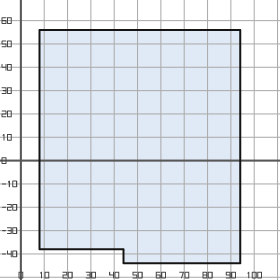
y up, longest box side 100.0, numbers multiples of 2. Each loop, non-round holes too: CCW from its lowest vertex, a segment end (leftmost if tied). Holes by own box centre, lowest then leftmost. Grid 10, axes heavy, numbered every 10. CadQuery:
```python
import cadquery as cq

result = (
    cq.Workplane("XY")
    .moveTo(44.0, -44.0)
    .lineTo(94.0, -44.0)
    .lineTo(94.0, 56.0)
    .lineTo(8.0, 56.0)
    .lineTo(8.0, -38.0)
    .lineTo(44.0, -38.0)
    .close()
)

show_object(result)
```